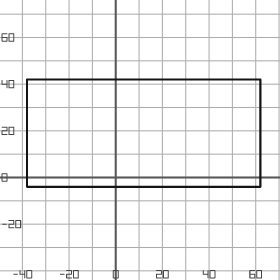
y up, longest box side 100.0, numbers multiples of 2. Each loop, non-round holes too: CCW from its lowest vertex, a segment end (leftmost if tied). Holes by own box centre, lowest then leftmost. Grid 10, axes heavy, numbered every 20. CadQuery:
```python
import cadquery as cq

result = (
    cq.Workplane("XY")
    .moveTo(-38.0, -4.0)
    .lineTo(62.0, -4.0)
    .lineTo(62.0, 42.0)
    .lineTo(-38.0, 42.0)
    .close()
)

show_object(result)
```